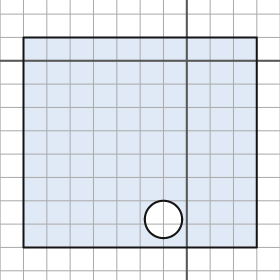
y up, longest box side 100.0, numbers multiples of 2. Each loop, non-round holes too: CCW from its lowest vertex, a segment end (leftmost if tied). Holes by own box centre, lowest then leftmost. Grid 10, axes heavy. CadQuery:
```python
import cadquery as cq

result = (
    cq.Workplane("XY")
    .moveTo(-70.0, -80.0)
    .lineTo(30.0, -80.0)
    .lineTo(30.0, 10.0)
    .lineTo(-70.0, 10.0)
    .close()
    .moveTo(-10.0, -68.0)
    .circle(8.0)
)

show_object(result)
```